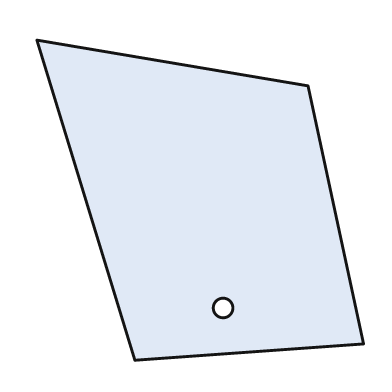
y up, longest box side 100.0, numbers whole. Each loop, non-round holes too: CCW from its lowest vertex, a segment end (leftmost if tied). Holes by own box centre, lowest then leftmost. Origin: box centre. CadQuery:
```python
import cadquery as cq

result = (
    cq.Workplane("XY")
    .moveTo(-20.0, -49.0)
    .lineTo(50.0, -44.0)
    .lineTo(33.0, 35.0)
    .lineTo(-50.0, 49.0)
    .close()
    .moveTo(7.0, -33.0)
    .circle(3.0)
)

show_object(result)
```